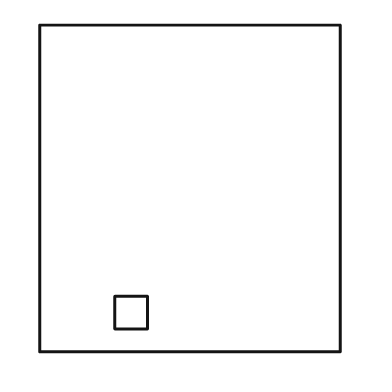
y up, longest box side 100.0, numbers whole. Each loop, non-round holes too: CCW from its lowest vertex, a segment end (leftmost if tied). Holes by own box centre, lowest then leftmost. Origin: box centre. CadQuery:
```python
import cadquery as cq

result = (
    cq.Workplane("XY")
    .moveTo(-46.0, -50.0)
    .lineTo(46.0, -50.0)
    .lineTo(46.0, 50.0)
    .lineTo(-46.0, 50.0)
    .close()
    .moveTo(-23.0, -43.0)
    .lineTo(-13.0, -43.0)
    .lineTo(-13.0, -33.0)
    .lineTo(-23.0, -33.0)
    .close()
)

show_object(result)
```